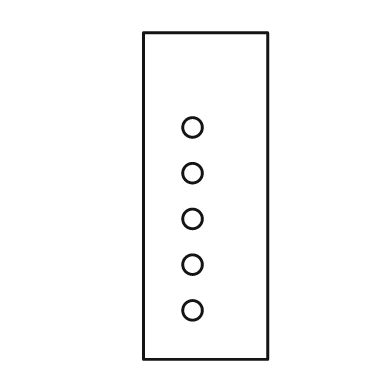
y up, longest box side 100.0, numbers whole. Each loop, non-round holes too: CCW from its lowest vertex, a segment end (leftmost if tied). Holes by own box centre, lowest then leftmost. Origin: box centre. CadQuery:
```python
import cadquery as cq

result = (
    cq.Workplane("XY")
    .moveTo(-19.0, -50.0)
    .lineTo(19.0, -50.0)
    .lineTo(19.0, 50.0)
    .lineTo(-19.0, 50.0)
    .close()
    .moveTo(-4.0, -35.0)
    .circle(3.0)
    .moveTo(-4.0, -21.0)
    .circle(3.0)
    .moveTo(-4.0, -7.0)
    .circle(3.0)
    .moveTo(-4.0, 7.0)
    .circle(3.0)
    .moveTo(-4.0, 21.0)
    .circle(3.0)
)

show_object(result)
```